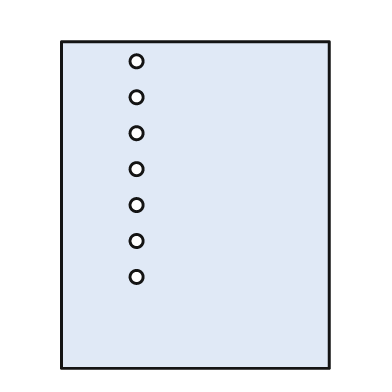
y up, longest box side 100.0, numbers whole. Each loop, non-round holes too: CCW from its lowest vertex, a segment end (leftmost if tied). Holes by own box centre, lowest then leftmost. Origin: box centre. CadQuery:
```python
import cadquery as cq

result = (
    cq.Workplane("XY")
    .moveTo(-41.0, -50.0)
    .lineTo(41.0, -50.0)
    .lineTo(41.0, 50.0)
    .lineTo(-41.0, 50.0)
    .close()
    .moveTo(-18.0, -22.0)
    .circle(2.0)
    .moveTo(-18.0, -11.0)
    .circle(2.0)
    .moveTo(-18.0, 0.0)
    .circle(2.0)
    .moveTo(-18.0, 11.0)
    .circle(2.0)
    .moveTo(-18.0, 22.0)
    .circle(2.0)
    .moveTo(-18.0, 33.0)
    .circle(2.0)
    .moveTo(-18.0, 44.0)
    .circle(2.0)
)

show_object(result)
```